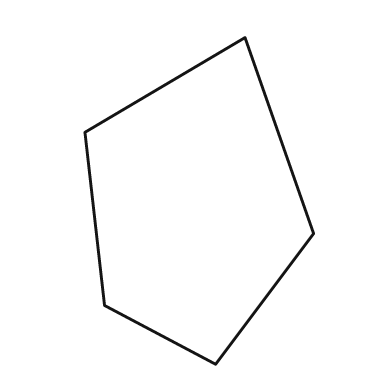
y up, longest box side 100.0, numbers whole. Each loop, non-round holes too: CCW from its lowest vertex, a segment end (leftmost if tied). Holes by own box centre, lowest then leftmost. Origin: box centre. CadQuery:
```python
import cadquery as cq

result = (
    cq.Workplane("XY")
    .moveTo(5.0, -50.0)
    .lineTo(35.0, -10.0)
    .lineTo(14.0, 50.0)
    .lineTo(-35.0, 21.0)
    .lineTo(-29.0, -32.0)
    .close()
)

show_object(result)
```